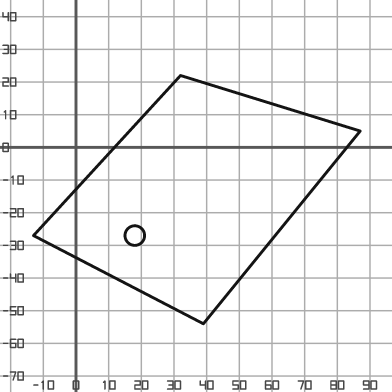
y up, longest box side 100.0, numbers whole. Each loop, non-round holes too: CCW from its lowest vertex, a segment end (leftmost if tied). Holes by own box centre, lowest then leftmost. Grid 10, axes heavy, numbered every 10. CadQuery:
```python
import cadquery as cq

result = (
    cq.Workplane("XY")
    .moveTo(39.0, -54.0)
    .lineTo(87.0, 5.0)
    .lineTo(32.0, 22.0)
    .lineTo(-13.0, -27.0)
    .close()
    .moveTo(18.0, -27.0)
    .circle(3.0)
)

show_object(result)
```